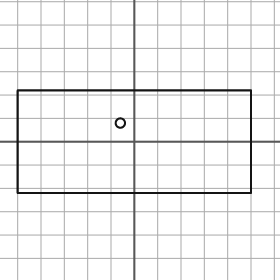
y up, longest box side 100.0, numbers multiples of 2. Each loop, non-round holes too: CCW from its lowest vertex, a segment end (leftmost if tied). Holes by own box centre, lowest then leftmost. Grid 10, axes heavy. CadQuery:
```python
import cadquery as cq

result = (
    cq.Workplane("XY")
    .moveTo(-50.0, -22.0)
    .lineTo(50.0, -22.0)
    .lineTo(50.0, 22.0)
    .lineTo(-50.0, 22.0)
    .close()
    .moveTo(-6.0, 8.0)
    .circle(2.0)
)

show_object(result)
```